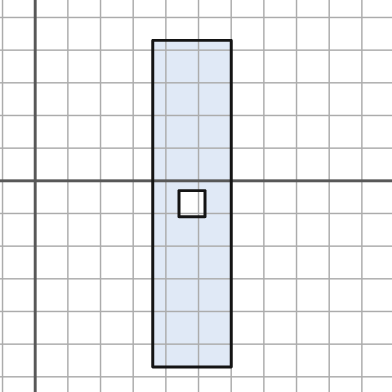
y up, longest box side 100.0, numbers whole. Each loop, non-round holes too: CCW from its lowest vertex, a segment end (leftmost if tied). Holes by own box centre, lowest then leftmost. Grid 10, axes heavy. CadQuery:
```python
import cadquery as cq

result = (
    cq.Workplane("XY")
    .moveTo(36.0, -57.0)
    .lineTo(60.0, -57.0)
    .lineTo(60.0, 43.0)
    .lineTo(36.0, 43.0)
    .close()
    .moveTo(44.0, -11.0)
    .lineTo(52.0, -11.0)
    .lineTo(52.0, -3.0)
    .lineTo(44.0, -3.0)
    .close()
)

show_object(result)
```